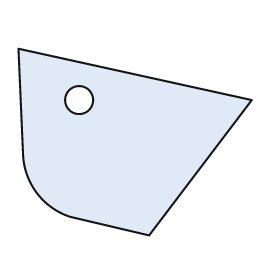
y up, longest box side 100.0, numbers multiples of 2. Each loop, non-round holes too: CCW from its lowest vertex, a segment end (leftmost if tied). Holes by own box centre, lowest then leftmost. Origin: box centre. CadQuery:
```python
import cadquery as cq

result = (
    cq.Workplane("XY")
    .moveTo(6.0, -40.0)
    .lineTo(50.0, 18.0)
    .lineTo(-50.0, 40.0)
    .lineTo(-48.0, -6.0)
    .threePointArc((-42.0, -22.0), (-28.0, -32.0))
    .close()
    .moveTo(-24.0, 18.0)
    .circle(6.0)
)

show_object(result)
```